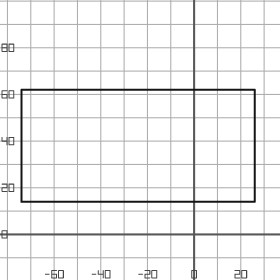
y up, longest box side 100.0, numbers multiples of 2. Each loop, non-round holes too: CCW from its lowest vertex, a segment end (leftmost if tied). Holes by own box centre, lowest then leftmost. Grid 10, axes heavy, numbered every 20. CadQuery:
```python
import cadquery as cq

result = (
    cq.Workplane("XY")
    .moveTo(-74.0, 14.0)
    .lineTo(26.0, 14.0)
    .lineTo(26.0, 62.0)
    .lineTo(-74.0, 62.0)
    .close()
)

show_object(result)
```